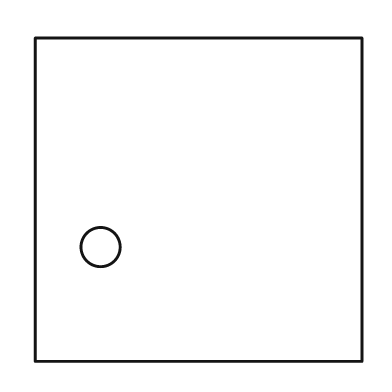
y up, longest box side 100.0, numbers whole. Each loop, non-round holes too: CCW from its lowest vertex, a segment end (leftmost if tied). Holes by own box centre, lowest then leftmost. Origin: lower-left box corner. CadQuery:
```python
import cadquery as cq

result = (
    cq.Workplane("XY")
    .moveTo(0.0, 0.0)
    .lineTo(100.0, 0.0)
    .lineTo(100.0, 99.0)
    .lineTo(0.0, 99.0)
    .close()
    .moveTo(20.0, 35.0)
    .circle(6.0)
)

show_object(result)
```